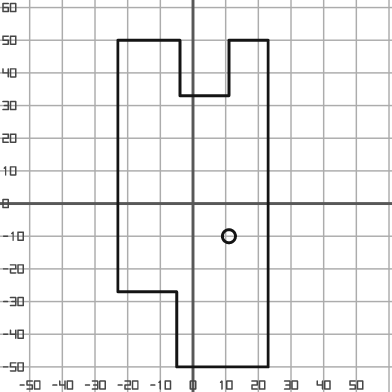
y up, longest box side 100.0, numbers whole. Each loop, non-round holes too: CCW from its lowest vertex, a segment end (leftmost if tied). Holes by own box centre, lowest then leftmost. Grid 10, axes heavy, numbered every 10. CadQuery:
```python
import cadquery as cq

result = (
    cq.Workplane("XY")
    .moveTo(-5.0, -50.0)
    .lineTo(23.0, -50.0)
    .lineTo(23.0, 50.0)
    .lineTo(11.0, 50.0)
    .lineTo(11.0, 33.0)
    .lineTo(-4.0, 33.0)
    .lineTo(-4.0, 50.0)
    .lineTo(-23.0, 50.0)
    .lineTo(-23.0, -27.0)
    .lineTo(-5.0, -27.0)
    .close()
    .moveTo(11.0, -10.0)
    .circle(2.0)
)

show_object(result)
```